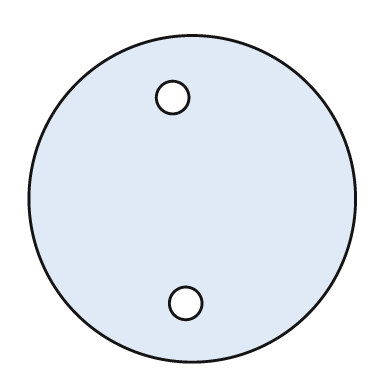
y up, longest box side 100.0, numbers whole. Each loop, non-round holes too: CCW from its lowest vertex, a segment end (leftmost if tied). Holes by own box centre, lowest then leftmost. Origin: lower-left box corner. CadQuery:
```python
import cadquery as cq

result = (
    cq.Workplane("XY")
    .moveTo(50.0, 50.0)
    .circle(50.0)
    .moveTo(48.0, 18.0)
    .circle(5.0)
    .moveTo(44.0, 81.0)
    .circle(5.0)
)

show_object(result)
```